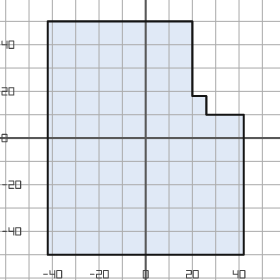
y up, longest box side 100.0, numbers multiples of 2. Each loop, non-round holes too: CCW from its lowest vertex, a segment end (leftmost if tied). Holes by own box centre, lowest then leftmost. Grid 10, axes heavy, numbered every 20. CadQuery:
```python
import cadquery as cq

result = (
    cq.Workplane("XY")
    .moveTo(-42.0, -50.0)
    .lineTo(42.0, -50.0)
    .lineTo(42.0, 10.0)
    .lineTo(26.0, 10.0)
    .lineTo(26.0, 18.0)
    .lineTo(20.0, 18.0)
    .lineTo(20.0, 50.0)
    .lineTo(-42.0, 50.0)
    .close()
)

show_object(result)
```